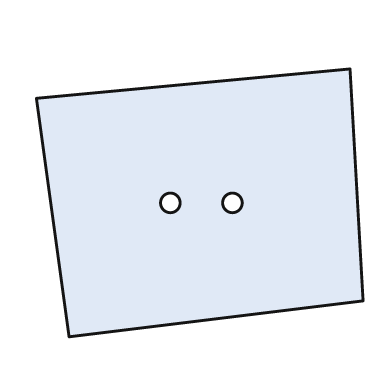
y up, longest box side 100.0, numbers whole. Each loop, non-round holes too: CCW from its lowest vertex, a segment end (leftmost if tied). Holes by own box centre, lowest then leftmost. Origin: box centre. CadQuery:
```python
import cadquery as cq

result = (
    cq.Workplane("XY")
    .moveTo(-40.0, -41.0)
    .lineTo(50.0, -30.0)
    .lineTo(46.0, 41.0)
    .lineTo(-50.0, 32.0)
    .close()
    .moveTo(-9.0, 0.0)
    .circle(3.0)
    .moveTo(10.0, 0.0)
    .circle(3.0)
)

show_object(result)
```